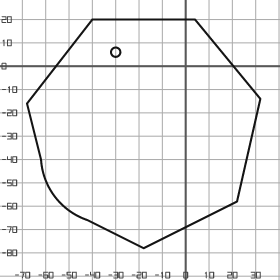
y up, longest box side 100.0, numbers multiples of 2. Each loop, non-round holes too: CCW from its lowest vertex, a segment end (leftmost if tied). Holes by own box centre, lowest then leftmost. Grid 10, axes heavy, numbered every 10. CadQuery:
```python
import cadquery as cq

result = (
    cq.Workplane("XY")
    .moveTo(-18.0, -78.0)
    .lineTo(22.0, -58.0)
    .lineTo(32.0, -14.0)
    .lineTo(4.0, 20.0)
    .lineTo(-40.0, 20.0)
    .lineTo(-68.0, -16.0)
    .lineTo(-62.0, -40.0)
    .threePointArc((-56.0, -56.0), (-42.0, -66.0))
    .close()
    .moveTo(-30.0, 6.0)
    .circle(2.0)
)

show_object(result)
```